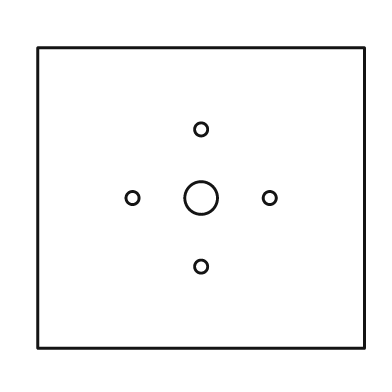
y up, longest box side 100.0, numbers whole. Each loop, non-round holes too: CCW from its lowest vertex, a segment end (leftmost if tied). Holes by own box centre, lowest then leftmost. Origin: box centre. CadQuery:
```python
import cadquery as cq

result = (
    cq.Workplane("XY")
    .moveTo(-50.0, -46.0)
    .lineTo(50.0, -46.0)
    .lineTo(50.0, 46.0)
    .lineTo(-50.0, 46.0)
    .close()
    .moveTo(0.0, -21.0)
    .circle(2.0)
    .moveTo(-21.0, 0.0)
    .circle(2.0)
    .moveTo(0.0, 0.0)
    .circle(5.0)
    .moveTo(21.0, 0.0)
    .circle(2.0)
    .moveTo(0.0, 21.0)
    .circle(2.0)
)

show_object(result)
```